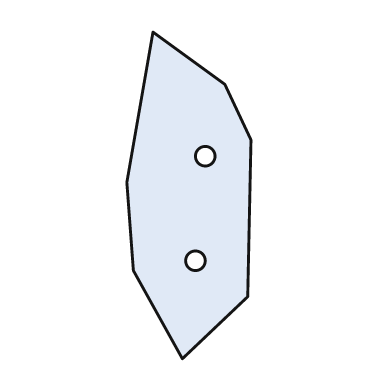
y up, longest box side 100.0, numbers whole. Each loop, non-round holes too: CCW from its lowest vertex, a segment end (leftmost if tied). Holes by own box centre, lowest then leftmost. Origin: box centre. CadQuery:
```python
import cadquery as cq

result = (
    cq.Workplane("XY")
    .moveTo(-2.0, -50.0)
    .lineTo(18.0, -31.0)
    .lineTo(19.0, 17.0)
    .lineTo(11.0, 34.0)
    .lineTo(-11.0, 50.0)
    .lineTo(-19.0, 4.0)
    .lineTo(-17.0, -23.0)
    .close()
    .moveTo(2.0, -20.0)
    .circle(3.0)
    .moveTo(5.0, 12.0)
    .circle(3.0)
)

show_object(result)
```